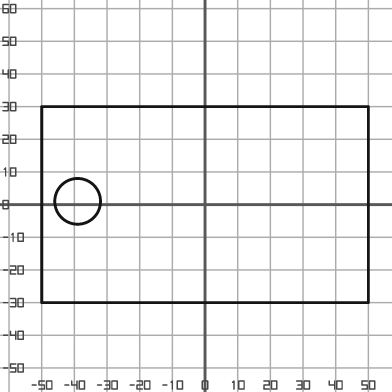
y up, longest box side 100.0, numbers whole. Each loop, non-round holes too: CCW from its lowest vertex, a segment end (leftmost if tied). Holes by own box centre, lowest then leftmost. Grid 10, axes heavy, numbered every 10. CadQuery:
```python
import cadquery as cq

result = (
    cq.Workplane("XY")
    .moveTo(-50.0, -30.0)
    .lineTo(50.0, -30.0)
    .lineTo(50.0, 30.0)
    .lineTo(-50.0, 30.0)
    .close()
    .moveTo(-39.0, 1.0)
    .circle(7.0)
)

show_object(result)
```